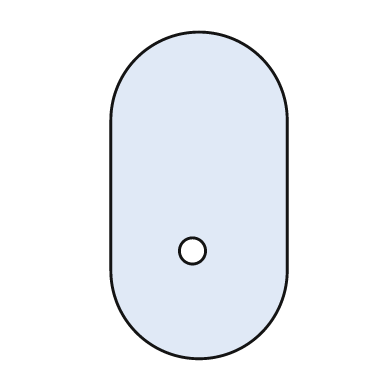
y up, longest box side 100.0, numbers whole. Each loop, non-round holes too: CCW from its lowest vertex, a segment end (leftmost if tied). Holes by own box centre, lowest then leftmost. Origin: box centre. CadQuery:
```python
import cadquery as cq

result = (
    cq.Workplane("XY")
    .moveTo(-27.0, -23.0)
    .threePointArc((0.0, -50.0), (27.0, -23.0))
    .lineTo(27.0, 23.0)
    .threePointArc((0.0, 50.0), (-27.0, 23.0))
    .close()
    .moveTo(-2.0, -17.0)
    .circle(4.0)
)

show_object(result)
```